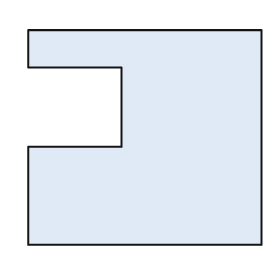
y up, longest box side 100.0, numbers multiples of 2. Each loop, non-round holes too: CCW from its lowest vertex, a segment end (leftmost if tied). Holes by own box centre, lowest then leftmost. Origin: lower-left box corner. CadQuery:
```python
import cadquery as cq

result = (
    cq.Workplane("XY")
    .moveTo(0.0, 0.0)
    .lineTo(100.0, 0.0)
    .lineTo(100.0, 92.0)
    .lineTo(0.0, 92.0)
    .lineTo(0.0, 76.0)
    .lineTo(40.0, 76.0)
    .lineTo(40.0, 42.0)
    .lineTo(0.0, 42.0)
    .close()
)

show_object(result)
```